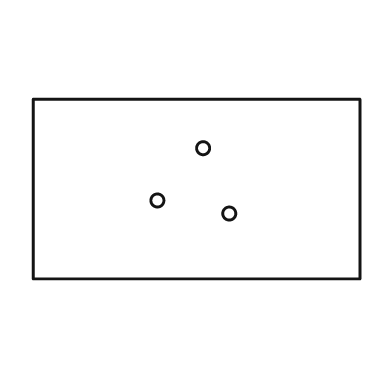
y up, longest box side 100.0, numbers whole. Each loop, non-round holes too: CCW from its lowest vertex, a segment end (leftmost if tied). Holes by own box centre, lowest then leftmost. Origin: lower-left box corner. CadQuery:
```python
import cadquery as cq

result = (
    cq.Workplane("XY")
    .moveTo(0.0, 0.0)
    .lineTo(100.0, 0.0)
    .lineTo(100.0, 55.0)
    .lineTo(0.0, 55.0)
    .close()
    .moveTo(60.0, 20.0)
    .circle(2.0)
    .moveTo(38.0, 24.0)
    .circle(2.0)
    .moveTo(52.0, 40.0)
    .circle(2.0)
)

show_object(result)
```